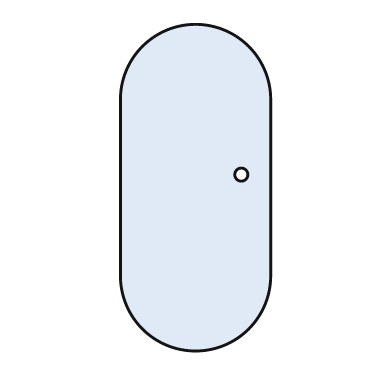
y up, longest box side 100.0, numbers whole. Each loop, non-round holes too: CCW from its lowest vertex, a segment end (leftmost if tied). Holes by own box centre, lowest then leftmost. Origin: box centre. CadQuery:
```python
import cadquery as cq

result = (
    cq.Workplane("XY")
    .moveTo(-23.0, -27.0)
    .threePointArc((0.0, -50.0), (23.0, -27.0))
    .lineTo(23.0, 27.0)
    .threePointArc((0.0, 50.0), (-23.0, 27.0))
    .close()
    .moveTo(14.0, 4.0)
    .circle(2.0)
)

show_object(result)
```